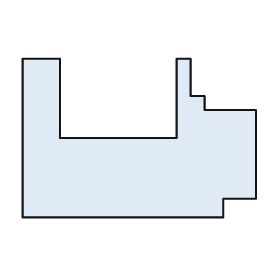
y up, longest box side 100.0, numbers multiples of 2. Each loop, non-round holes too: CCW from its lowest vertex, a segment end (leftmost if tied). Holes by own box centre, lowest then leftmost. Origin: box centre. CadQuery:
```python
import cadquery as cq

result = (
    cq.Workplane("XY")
    .moveTo(-50.0, -34.0)
    .lineTo(36.0, -34.0)
    .lineTo(36.0, -26.0)
    .lineTo(50.0, -26.0)
    .lineTo(50.0, 12.0)
    .lineTo(28.0, 12.0)
    .lineTo(28.0, 18.0)
    .lineTo(22.0, 18.0)
    .lineTo(22.0, 34.0)
    .lineTo(16.0, 34.0)
    .lineTo(16.0, 0.0)
    .lineTo(-34.0, 0.0)
    .lineTo(-34.0, 34.0)
    .lineTo(-50.0, 34.0)
    .close()
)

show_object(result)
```